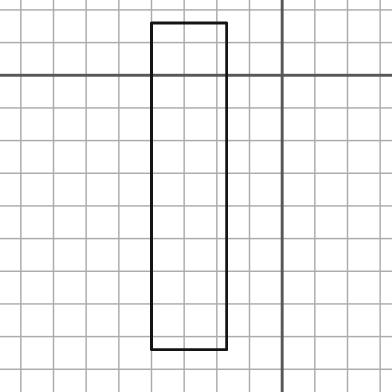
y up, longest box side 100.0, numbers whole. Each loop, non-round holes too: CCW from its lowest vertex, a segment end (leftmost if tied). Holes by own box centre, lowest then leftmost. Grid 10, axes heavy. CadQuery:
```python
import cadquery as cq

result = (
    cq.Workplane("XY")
    .moveTo(-40.0, -84.0)
    .lineTo(-17.0, -84.0)
    .lineTo(-17.0, 16.0)
    .lineTo(-40.0, 16.0)
    .close()
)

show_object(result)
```